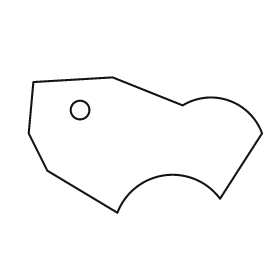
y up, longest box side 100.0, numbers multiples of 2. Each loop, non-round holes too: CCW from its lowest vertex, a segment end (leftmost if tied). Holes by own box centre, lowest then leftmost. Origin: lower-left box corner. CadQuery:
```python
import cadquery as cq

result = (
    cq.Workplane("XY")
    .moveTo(38.0, 0.0)
    .threePointArc((58.0, 16.0), (82.0, 6.0))
    .lineTo(100.0, 34.0)
    .threePointArc((86.0, 48.0), (66.0, 46.0))
    .lineTo(36.0, 58.0)
    .lineTo(2.0, 56.0)
    .lineTo(0.0, 34.0)
    .lineTo(8.0, 18.0)
    .close()
    .moveTo(22.0, 44.0)
    .circle(4.0)
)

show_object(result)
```